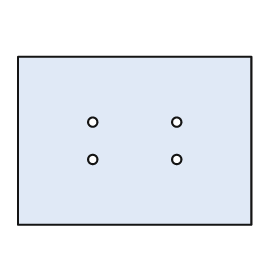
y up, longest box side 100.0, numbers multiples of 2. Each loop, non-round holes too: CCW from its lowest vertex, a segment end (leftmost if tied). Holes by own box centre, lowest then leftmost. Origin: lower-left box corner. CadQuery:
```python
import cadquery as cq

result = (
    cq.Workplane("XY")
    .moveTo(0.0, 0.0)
    .lineTo(100.0, 0.0)
    .lineTo(100.0, 72.0)
    .lineTo(0.0, 72.0)
    .close()
    .moveTo(32.0, 28.0)
    .circle(2.0)
    .moveTo(68.0, 28.0)
    .circle(2.0)
    .moveTo(32.0, 44.0)
    .circle(2.0)
    .moveTo(68.0, 44.0)
    .circle(2.0)
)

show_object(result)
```